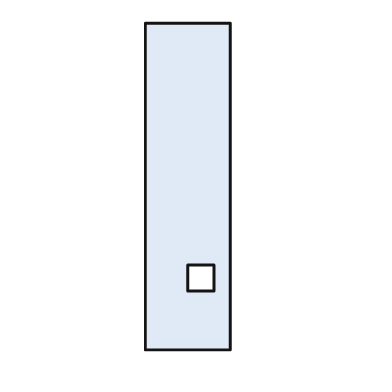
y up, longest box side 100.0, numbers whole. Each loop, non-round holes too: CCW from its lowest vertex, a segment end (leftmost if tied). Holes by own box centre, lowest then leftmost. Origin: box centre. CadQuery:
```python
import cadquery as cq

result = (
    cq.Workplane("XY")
    .moveTo(-13.0, -50.0)
    .lineTo(13.0, -50.0)
    .lineTo(13.0, 50.0)
    .lineTo(-13.0, 50.0)
    .close()
    .moveTo(0.0, -32.0)
    .lineTo(8.0, -32.0)
    .lineTo(8.0, -24.0)
    .lineTo(0.0, -24.0)
    .close()
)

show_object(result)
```